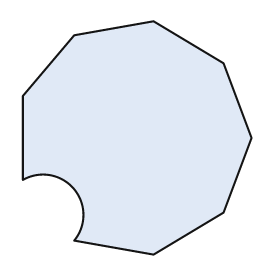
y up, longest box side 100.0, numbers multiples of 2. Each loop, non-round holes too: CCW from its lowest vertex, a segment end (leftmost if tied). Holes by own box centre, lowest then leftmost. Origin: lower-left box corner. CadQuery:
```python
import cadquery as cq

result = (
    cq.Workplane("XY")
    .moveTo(56.0, 0.0)
    .lineTo(86.0, 18.0)
    .lineTo(98.0, 50.0)
    .lineTo(86.0, 82.0)
    .lineTo(56.0, 100.0)
    .lineTo(22.0, 94.0)
    .lineTo(0.0, 68.0)
    .lineTo(0.0, 32.0)
    .threePointArc((22.0, 28.0), (22.0, 6.0))
    .close()
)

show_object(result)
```